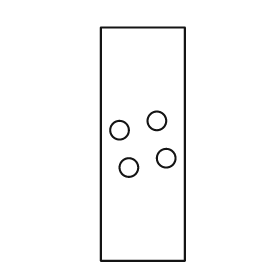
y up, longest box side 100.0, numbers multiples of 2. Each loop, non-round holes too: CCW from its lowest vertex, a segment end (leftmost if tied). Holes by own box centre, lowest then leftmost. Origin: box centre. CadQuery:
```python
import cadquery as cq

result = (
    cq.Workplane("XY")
    .moveTo(-18.0, -50.0)
    .lineTo(18.0, -50.0)
    .lineTo(18.0, 50.0)
    .lineTo(-18.0, 50.0)
    .close()
    .moveTo(-6.0, -10.0)
    .circle(4.0)
    .moveTo(10.0, -6.0)
    .circle(4.0)
    .moveTo(-10.0, 6.0)
    .circle(4.0)
    .moveTo(6.0, 10.0)
    .circle(4.0)
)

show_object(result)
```